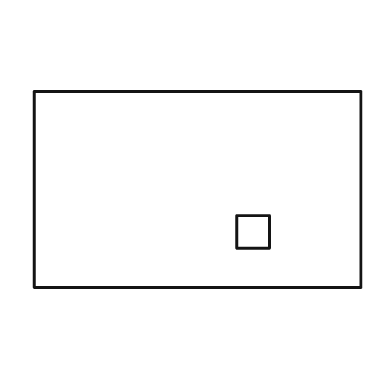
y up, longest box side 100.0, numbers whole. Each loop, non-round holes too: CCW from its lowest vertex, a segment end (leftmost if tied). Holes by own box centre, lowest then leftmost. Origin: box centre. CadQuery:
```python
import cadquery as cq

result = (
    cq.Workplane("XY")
    .moveTo(-50.0, -30.0)
    .lineTo(50.0, -30.0)
    .lineTo(50.0, 30.0)
    .lineTo(-50.0, 30.0)
    .close()
    .moveTo(12.0, -18.0)
    .lineTo(22.0, -18.0)
    .lineTo(22.0, -8.0)
    .lineTo(12.0, -8.0)
    .close()
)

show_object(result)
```